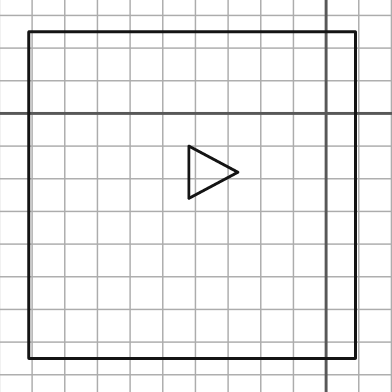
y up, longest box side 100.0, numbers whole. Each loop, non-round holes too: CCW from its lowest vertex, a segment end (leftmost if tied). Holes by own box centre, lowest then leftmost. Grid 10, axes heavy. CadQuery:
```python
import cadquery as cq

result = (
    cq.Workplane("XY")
    .moveTo(-91.0, -75.0)
    .lineTo(9.0, -75.0)
    .lineTo(9.0, 25.0)
    .lineTo(-91.0, 25.0)
    .close()
    .moveTo(-42.0, -26.0)
    .lineTo(-27.0, -18.0)
    .lineTo(-42.0, -10.0)
    .close()
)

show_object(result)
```